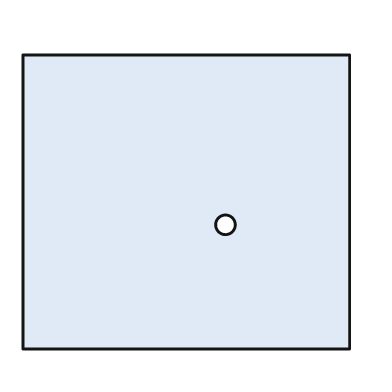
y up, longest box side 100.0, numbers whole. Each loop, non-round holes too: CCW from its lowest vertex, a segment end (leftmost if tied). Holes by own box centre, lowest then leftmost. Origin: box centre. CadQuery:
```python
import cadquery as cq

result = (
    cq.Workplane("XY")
    .moveTo(-50.0, -45.0)
    .lineTo(50.0, -45.0)
    .lineTo(50.0, 45.0)
    .lineTo(-50.0, 45.0)
    .close()
    .moveTo(12.0, -7.0)
    .circle(3.0)
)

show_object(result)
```